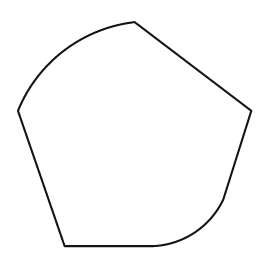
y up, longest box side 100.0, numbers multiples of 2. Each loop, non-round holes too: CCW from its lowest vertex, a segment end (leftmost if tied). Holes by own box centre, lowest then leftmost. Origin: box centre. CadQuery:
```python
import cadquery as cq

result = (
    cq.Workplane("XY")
    .moveTo(-30.0, -48.0)
    .lineTo(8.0, -48.0)
    .threePointArc((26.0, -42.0), (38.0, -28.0))
    .lineTo(50.0, 10.0)
    .lineTo(0.0, 48.0)
    .threePointArc((-30.0, 36.0), (-50.0, 10.0))
    .close()
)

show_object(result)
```